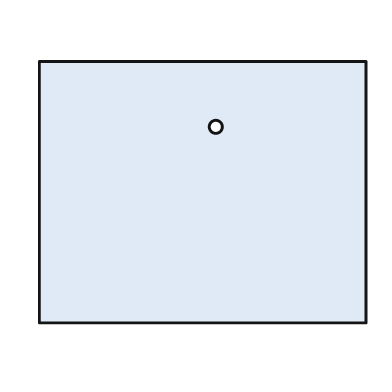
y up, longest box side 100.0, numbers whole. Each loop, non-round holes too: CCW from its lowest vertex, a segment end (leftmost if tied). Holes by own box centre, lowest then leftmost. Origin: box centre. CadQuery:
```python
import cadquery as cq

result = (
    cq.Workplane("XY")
    .moveTo(-50.0, -40.0)
    .lineTo(50.0, -40.0)
    .lineTo(50.0, 40.0)
    .lineTo(-50.0, 40.0)
    .close()
    .moveTo(4.0, 20.0)
    .circle(2.0)
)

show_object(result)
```